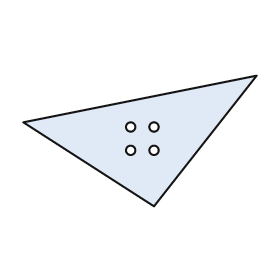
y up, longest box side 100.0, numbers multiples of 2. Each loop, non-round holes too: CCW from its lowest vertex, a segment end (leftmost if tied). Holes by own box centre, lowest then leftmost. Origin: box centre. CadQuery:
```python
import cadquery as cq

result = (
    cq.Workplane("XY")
    .moveTo(6.0, -28.0)
    .lineTo(50.0, 28.0)
    .lineTo(-50.0, 8.0)
    .close()
    .moveTo(-4.0, -4.0)
    .circle(2.0)
    .moveTo(6.0, -4.0)
    .circle(2.0)
    .moveTo(-4.0, 6.0)
    .circle(2.0)
    .moveTo(6.0, 6.0)
    .circle(2.0)
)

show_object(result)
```